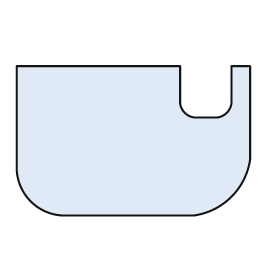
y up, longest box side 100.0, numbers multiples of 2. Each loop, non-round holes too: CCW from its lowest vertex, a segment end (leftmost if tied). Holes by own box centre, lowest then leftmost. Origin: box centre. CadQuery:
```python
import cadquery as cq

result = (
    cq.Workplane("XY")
    .moveTo(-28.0, -32.0)
    .lineTo(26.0, -32.0)
    .threePointArc((42.0, -24.0), (50.0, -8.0))
    .lineTo(50.0, 32.0)
    .lineTo(42.0, 32.0)
    .lineTo(42.0, 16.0)
    .threePointArc((40.0, 12.0), (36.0, 10.0))
    .lineTo(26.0, 10.0)
    .threePointArc((22.0, 12.0), (20.0, 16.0))
    .lineTo(20.0, 32.0)
    .lineTo(-50.0, 32.0)
    .lineTo(-50.0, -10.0)
    .threePointArc((-44.0, -26.0), (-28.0, -32.0))
    .close()
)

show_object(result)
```